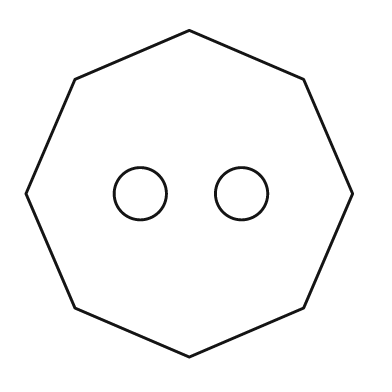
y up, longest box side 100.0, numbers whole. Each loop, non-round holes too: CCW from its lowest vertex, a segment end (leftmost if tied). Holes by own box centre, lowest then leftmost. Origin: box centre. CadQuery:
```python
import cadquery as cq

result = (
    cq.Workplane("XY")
    .moveTo(0.0, -50.0)
    .lineTo(35.0, -35.0)
    .lineTo(50.0, 0.0)
    .lineTo(35.0, 35.0)
    .lineTo(0.0, 50.0)
    .lineTo(-35.0, 35.0)
    .lineTo(-50.0, 0.0)
    .lineTo(-35.0, -35.0)
    .close()
    .moveTo(-15.0, 0.0)
    .circle(8.0)
    .moveTo(16.0, 0.0)
    .circle(8.0)
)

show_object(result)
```